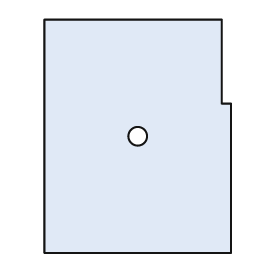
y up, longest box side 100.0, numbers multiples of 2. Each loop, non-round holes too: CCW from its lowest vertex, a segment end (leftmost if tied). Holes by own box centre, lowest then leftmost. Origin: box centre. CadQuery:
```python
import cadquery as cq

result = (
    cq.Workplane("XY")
    .moveTo(-40.0, -50.0)
    .lineTo(40.0, -50.0)
    .lineTo(40.0, 14.0)
    .lineTo(36.0, 14.0)
    .lineTo(36.0, 50.0)
    .lineTo(-40.0, 50.0)
    .close()
    .moveTo(0.0, 0.0)
    .circle(4.0)
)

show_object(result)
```